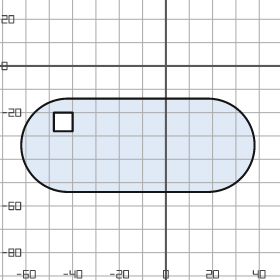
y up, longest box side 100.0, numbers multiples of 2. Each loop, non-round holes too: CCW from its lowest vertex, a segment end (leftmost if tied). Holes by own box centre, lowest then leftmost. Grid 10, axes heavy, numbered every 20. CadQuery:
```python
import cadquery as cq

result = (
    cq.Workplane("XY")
    .moveTo(-42.0, -54.0)
    .lineTo(18.0, -54.0)
    .threePointArc((38.0, -34.0), (18.0, -14.0))
    .lineTo(-42.0, -14.0)
    .threePointArc((-62.0, -34.0), (-42.0, -54.0))
    .close()
    .moveTo(-48.0, -28.0)
    .lineTo(-40.0, -28.0)
    .lineTo(-40.0, -20.0)
    .lineTo(-48.0, -20.0)
    .close()
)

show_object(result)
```